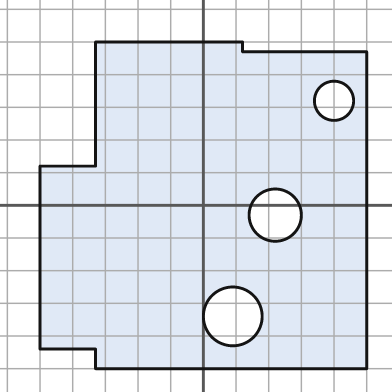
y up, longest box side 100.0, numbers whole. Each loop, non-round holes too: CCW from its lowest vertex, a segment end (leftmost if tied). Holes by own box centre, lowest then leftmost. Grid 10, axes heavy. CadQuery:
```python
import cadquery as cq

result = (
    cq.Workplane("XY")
    .moveTo(-33.0, -50.0)
    .lineTo(50.0, -50.0)
    .lineTo(50.0, 47.0)
    .lineTo(12.0, 47.0)
    .lineTo(12.0, 50.0)
    .lineTo(-33.0, 50.0)
    .lineTo(-33.0, 12.0)
    .lineTo(-50.0, 12.0)
    .lineTo(-50.0, -44.0)
    .lineTo(-33.0, -44.0)
    .close()
    .moveTo(9.0, -34.0)
    .circle(9.0)
    .moveTo(22.0, -3.0)
    .circle(8.0)
    .moveTo(40.0, 32.0)
    .circle(6.0)
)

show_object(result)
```